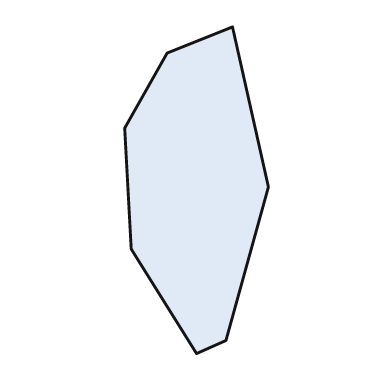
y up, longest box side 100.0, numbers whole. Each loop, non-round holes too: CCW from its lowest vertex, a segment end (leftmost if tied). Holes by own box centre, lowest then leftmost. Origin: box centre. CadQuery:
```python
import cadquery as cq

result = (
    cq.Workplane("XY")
    .moveTo(0.0, -50.0)
    .lineTo(9.0, -46.0)
    .lineTo(22.0, 1.0)
    .lineTo(11.0, 50.0)
    .lineTo(-9.0, 42.0)
    .lineTo(-22.0, 19.0)
    .lineTo(-20.0, -18.0)
    .close()
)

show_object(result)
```